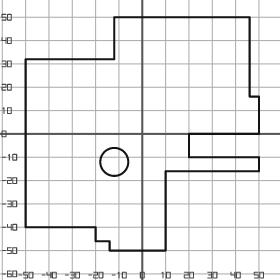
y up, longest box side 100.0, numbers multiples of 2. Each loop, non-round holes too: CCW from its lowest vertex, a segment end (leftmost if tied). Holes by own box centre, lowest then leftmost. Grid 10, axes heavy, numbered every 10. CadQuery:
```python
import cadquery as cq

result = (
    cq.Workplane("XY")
    .moveTo(-14.0, -50.0)
    .lineTo(10.0, -50.0)
    .lineTo(10.0, -16.0)
    .lineTo(50.0, -16.0)
    .lineTo(50.0, -10.0)
    .lineTo(20.0, -10.0)
    .lineTo(20.0, 0.0)
    .lineTo(50.0, 0.0)
    .lineTo(50.0, 16.0)
    .lineTo(46.0, 16.0)
    .lineTo(46.0, 50.0)
    .lineTo(-12.0, 50.0)
    .lineTo(-12.0, 32.0)
    .lineTo(-50.0, 32.0)
    .lineTo(-50.0, -40.0)
    .lineTo(-20.0, -40.0)
    .lineTo(-20.0, -46.0)
    .lineTo(-14.0, -46.0)
    .close()
    .moveTo(-12.0, -12.0)
    .circle(6.0)
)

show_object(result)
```